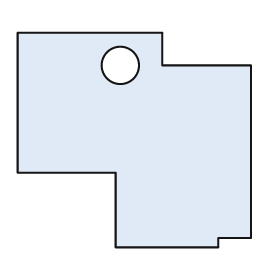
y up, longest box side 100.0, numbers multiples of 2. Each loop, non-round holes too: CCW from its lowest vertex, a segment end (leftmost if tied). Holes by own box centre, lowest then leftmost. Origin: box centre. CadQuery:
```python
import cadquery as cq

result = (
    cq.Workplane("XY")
    .moveTo(-8.0, -46.0)
    .lineTo(36.0, -46.0)
    .lineTo(36.0, -42.0)
    .lineTo(50.0, -42.0)
    .lineTo(50.0, 32.0)
    .lineTo(12.0, 32.0)
    .lineTo(12.0, 46.0)
    .lineTo(-50.0, 46.0)
    .lineTo(-50.0, -14.0)
    .lineTo(-8.0, -14.0)
    .close()
    .moveTo(-6.0, 32.0)
    .circle(8.0)
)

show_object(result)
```